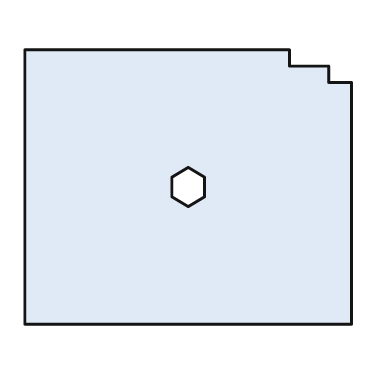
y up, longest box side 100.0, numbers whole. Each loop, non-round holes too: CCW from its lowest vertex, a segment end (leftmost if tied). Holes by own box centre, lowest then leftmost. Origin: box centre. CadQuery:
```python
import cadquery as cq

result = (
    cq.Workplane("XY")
    .moveTo(-50.0, -42.0)
    .lineTo(50.0, -42.0)
    .lineTo(50.0, 32.0)
    .lineTo(43.0, 32.0)
    .lineTo(43.0, 37.0)
    .lineTo(31.0, 37.0)
    .lineTo(31.0, 42.0)
    .lineTo(-50.0, 42.0)
    .close()
    .moveTo(0.0, -6.0)
    .lineTo(5.0, -3.0)
    .lineTo(5.0, 3.0)
    .lineTo(0.0, 6.0)
    .lineTo(-5.0, 3.0)
    .lineTo(-5.0, -3.0)
    .close()
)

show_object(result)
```